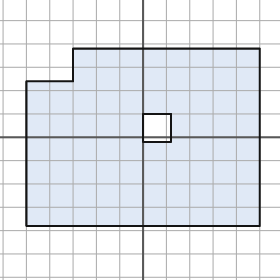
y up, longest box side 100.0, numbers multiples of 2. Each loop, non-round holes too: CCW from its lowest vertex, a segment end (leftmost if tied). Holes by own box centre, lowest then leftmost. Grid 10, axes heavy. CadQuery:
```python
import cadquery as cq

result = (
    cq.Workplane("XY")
    .moveTo(-50.0, -38.0)
    .lineTo(50.0, -38.0)
    .lineTo(50.0, 38.0)
    .lineTo(-30.0, 38.0)
    .lineTo(-30.0, 24.0)
    .lineTo(-50.0, 24.0)
    .close()
    .moveTo(0.0, -2.0)
    .lineTo(12.0, -2.0)
    .lineTo(12.0, 10.0)
    .lineTo(0.0, 10.0)
    .close()
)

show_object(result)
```